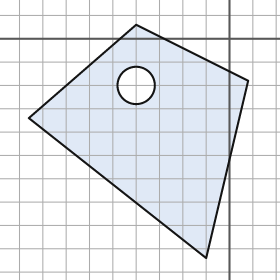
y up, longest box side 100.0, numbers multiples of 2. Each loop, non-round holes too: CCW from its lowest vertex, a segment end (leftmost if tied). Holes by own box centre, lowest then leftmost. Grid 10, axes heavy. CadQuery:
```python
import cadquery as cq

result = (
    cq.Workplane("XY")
    .moveTo(-10.0, -94.0)
    .lineTo(8.0, -18.0)
    .lineTo(-40.0, 6.0)
    .lineTo(-86.0, -34.0)
    .close()
    .moveTo(-40.0, -20.0)
    .circle(8.0)
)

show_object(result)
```